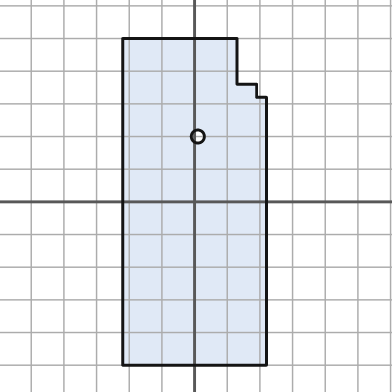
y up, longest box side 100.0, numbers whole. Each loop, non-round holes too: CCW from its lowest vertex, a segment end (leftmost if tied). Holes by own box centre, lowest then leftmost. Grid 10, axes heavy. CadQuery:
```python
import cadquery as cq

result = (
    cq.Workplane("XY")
    .moveTo(-22.0, -50.0)
    .lineTo(22.0, -50.0)
    .lineTo(22.0, 32.0)
    .lineTo(19.0, 32.0)
    .lineTo(19.0, 36.0)
    .lineTo(13.0, 36.0)
    .lineTo(13.0, 50.0)
    .lineTo(-22.0, 50.0)
    .close()
    .moveTo(1.0, 20.0)
    .circle(2.0)
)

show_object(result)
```